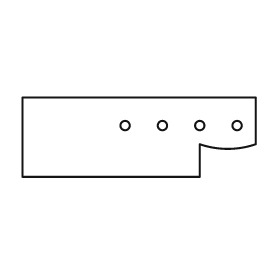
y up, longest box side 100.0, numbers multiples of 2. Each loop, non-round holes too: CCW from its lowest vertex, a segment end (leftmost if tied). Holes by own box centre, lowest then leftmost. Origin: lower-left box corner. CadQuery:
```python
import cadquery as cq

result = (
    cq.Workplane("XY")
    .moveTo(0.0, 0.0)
    .lineTo(76.0, 0.0)
    .lineTo(76.0, 14.0)
    .threePointArc((88.0, 12.0), (100.0, 14.0))
    .lineTo(100.0, 34.0)
    .lineTo(0.0, 34.0)
    .close()
    .moveTo(44.0, 22.0)
    .circle(2.0)
    .moveTo(60.0, 22.0)
    .circle(2.0)
    .moveTo(76.0, 22.0)
    .circle(2.0)
    .moveTo(92.0, 22.0)
    .circle(2.0)
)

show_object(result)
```